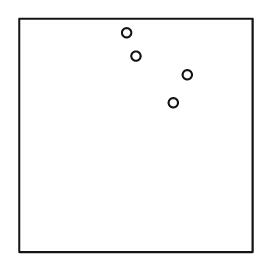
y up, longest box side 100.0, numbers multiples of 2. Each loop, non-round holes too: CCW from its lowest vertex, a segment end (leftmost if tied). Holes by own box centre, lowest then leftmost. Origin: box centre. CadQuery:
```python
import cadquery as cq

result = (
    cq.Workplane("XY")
    .moveTo(-50.0, -50.0)
    .lineTo(50.0, -50.0)
    .lineTo(50.0, 50.0)
    .lineTo(-50.0, 50.0)
    .close()
    .moveTo(16.0, 14.0)
    .circle(2.0)
    .moveTo(22.0, 26.0)
    .circle(2.0)
    .moveTo(0.0, 34.0)
    .circle(2.0)
    .moveTo(-4.0, 44.0)
    .circle(2.0)
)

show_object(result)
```